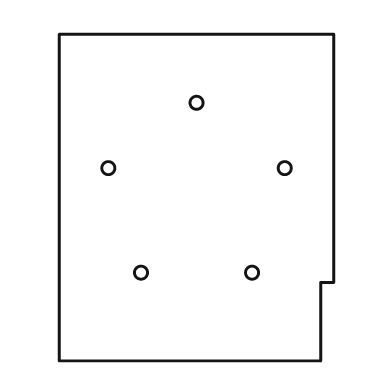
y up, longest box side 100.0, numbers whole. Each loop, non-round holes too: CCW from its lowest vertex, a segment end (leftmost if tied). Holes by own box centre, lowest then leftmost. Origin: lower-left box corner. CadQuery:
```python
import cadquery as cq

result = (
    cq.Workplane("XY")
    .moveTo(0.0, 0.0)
    .lineTo(80.0, 0.0)
    .lineTo(80.0, 24.0)
    .lineTo(84.0, 24.0)
    .lineTo(84.0, 100.0)
    .lineTo(0.0, 100.0)
    .close()
    .moveTo(25.0, 27.0)
    .circle(2.0)
    .moveTo(59.0, 27.0)
    .circle(2.0)
    .moveTo(15.0, 59.0)
    .circle(2.0)
    .moveTo(69.0, 59.0)
    .circle(2.0)
    .moveTo(42.0, 79.0)
    .circle(2.0)
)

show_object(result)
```